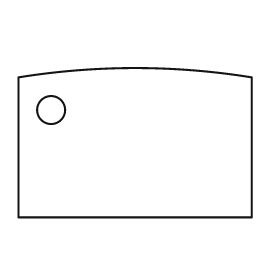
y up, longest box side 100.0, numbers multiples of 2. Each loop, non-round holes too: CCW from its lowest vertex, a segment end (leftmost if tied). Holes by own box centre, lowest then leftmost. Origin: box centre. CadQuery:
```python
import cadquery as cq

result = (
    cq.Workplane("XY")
    .moveTo(-50.0, -32.0)
    .lineTo(50.0, -32.0)
    .lineTo(50.0, 28.0)
    .threePointArc((0.0, 32.0), (-50.0, 28.0))
    .close()
    .moveTo(-36.0, 14.0)
    .circle(6.0)
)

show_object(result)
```